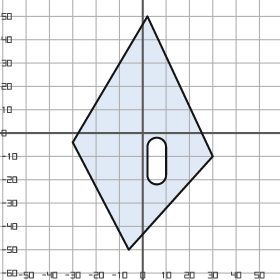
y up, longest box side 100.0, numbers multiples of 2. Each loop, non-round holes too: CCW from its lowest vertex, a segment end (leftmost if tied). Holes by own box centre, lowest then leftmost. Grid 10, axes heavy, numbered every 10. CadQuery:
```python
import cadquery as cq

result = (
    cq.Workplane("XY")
    .moveTo(-6.0, -50.0)
    .lineTo(30.0, -10.0)
    .lineTo(2.0, 50.0)
    .lineTo(-30.0, -4.0)
    .close()
    .moveTo(2.0, -18.0)
    .threePointArc((6.0, -22.0), (10.0, -18.0))
    .lineTo(10.0, -6.0)
    .threePointArc((6.0, -2.0), (2.0, -6.0))
    .close()
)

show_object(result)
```